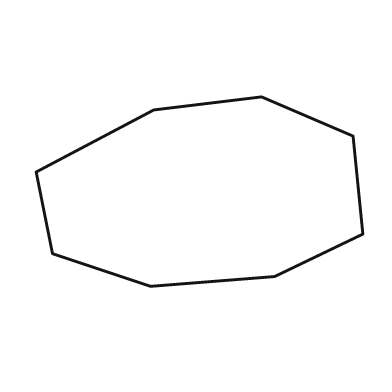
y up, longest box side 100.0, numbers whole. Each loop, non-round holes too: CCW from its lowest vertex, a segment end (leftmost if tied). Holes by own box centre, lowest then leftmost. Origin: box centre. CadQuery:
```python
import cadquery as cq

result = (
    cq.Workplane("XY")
    .moveTo(-15.0, -29.0)
    .lineTo(23.0, -26.0)
    .lineTo(50.0, -13.0)
    .lineTo(47.0, 17.0)
    .lineTo(19.0, 29.0)
    .lineTo(-14.0, 25.0)
    .lineTo(-50.0, 6.0)
    .lineTo(-45.0, -19.0)
    .close()
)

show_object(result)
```